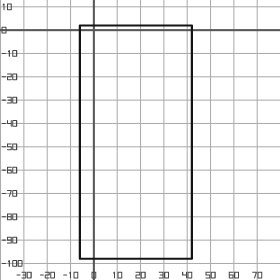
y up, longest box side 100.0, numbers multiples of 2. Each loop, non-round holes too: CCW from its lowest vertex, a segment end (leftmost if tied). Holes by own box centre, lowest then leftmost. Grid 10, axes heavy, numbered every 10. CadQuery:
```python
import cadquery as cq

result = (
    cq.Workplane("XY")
    .moveTo(-6.0, -98.0)
    .lineTo(42.0, -98.0)
    .lineTo(42.0, 2.0)
    .lineTo(-6.0, 2.0)
    .close()
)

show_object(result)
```